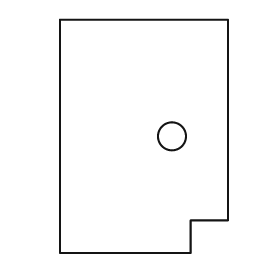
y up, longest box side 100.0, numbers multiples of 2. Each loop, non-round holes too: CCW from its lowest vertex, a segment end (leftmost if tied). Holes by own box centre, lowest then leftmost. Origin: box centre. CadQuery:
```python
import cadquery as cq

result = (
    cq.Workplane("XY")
    .moveTo(-36.0, -50.0)
    .lineTo(20.0, -50.0)
    .lineTo(20.0, -36.0)
    .lineTo(36.0, -36.0)
    .lineTo(36.0, 50.0)
    .lineTo(-36.0, 50.0)
    .close()
    .moveTo(12.0, 0.0)
    .circle(6.0)
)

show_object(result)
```